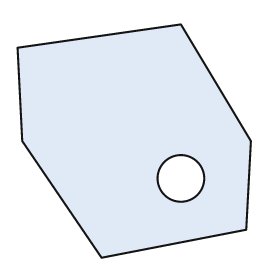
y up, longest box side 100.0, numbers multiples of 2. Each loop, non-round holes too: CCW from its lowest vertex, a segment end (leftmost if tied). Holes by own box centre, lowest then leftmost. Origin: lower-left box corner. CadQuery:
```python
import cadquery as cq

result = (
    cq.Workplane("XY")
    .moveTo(36.0, 0.0)
    .lineTo(98.0, 12.0)
    .lineTo(100.0, 50.0)
    .lineTo(70.0, 100.0)
    .lineTo(0.0, 90.0)
    .lineTo(2.0, 50.0)
    .close()
    .moveTo(70.0, 34.0)
    .circle(10.0)
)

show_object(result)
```